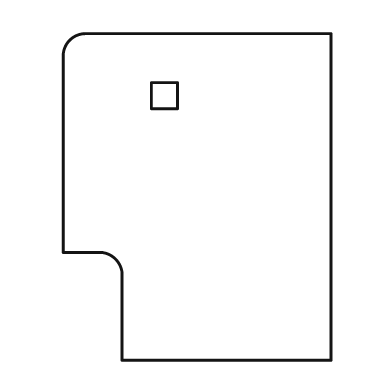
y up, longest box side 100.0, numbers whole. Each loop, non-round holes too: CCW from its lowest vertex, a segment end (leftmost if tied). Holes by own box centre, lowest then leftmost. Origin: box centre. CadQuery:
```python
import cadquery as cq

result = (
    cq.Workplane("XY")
    .moveTo(-23.0, -50.0)
    .lineTo(41.0, -50.0)
    .lineTo(41.0, 50.0)
    .lineTo(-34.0, 50.0)
    .threePointArc((-39.0, 48.0), (-41.0, 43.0))
    .lineTo(-41.0, -17.0)
    .lineTo(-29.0, -17.0)
    .threePointArc((-25.0, -19.0), (-23.0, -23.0))
    .close()
    .moveTo(-14.0, 27.0)
    .lineTo(-6.0, 27.0)
    .lineTo(-6.0, 35.0)
    .lineTo(-14.0, 35.0)
    .close()
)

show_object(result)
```